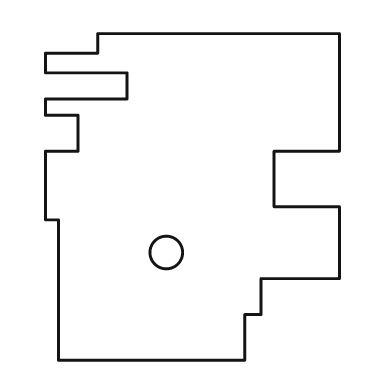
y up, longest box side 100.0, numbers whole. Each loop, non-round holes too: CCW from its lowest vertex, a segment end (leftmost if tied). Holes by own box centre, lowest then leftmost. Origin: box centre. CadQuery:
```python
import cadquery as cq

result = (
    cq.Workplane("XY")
    .moveTo(-41.0, -50.0)
    .lineTo(16.0, -50.0)
    .lineTo(16.0, -36.0)
    .lineTo(21.0, -36.0)
    .lineTo(21.0, -25.0)
    .lineTo(45.0, -25.0)
    .lineTo(45.0, -3.0)
    .lineTo(25.0, -3.0)
    .lineTo(25.0, 14.0)
    .lineTo(45.0, 14.0)
    .lineTo(45.0, 50.0)
    .lineTo(-29.0, 50.0)
    .lineTo(-29.0, 44.0)
    .lineTo(-45.0, 44.0)
    .lineTo(-45.0, 38.0)
    .lineTo(-20.0, 38.0)
    .lineTo(-20.0, 30.0)
    .lineTo(-45.0, 30.0)
    .lineTo(-45.0, 25.0)
    .lineTo(-35.0, 25.0)
    .lineTo(-35.0, 14.0)
    .lineTo(-45.0, 14.0)
    .lineTo(-45.0, -7.0)
    .lineTo(-41.0, -7.0)
    .close()
    .moveTo(-8.0, -17.0)
    .circle(5.0)
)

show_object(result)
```